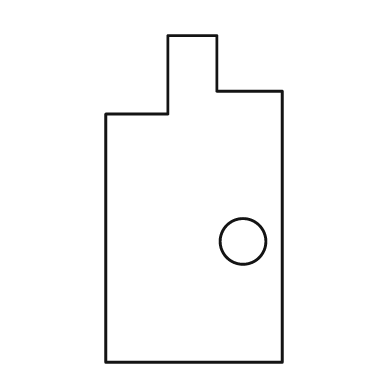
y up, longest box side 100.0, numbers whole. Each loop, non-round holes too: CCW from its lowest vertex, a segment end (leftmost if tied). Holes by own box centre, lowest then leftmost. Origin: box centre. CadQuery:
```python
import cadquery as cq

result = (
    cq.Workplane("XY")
    .moveTo(-27.0, -50.0)
    .lineTo(27.0, -50.0)
    .lineTo(27.0, 33.0)
    .lineTo(7.0, 33.0)
    .lineTo(7.0, 50.0)
    .lineTo(-8.0, 50.0)
    .lineTo(-8.0, 26.0)
    .lineTo(-27.0, 26.0)
    .close()
    .moveTo(15.0, -13.0)
    .circle(7.0)
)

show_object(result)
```